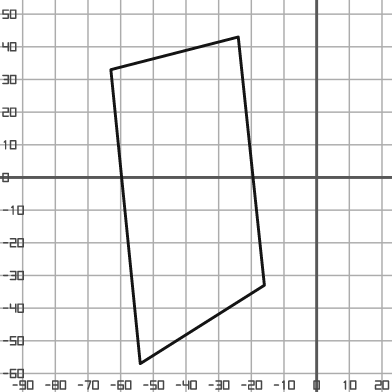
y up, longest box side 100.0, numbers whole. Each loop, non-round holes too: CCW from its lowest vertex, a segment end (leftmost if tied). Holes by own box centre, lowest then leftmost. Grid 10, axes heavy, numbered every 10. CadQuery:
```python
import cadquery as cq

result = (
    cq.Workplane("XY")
    .moveTo(-54.0, -57.0)
    .lineTo(-16.0, -33.0)
    .lineTo(-24.0, 43.0)
    .lineTo(-63.0, 33.0)
    .close()
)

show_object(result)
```